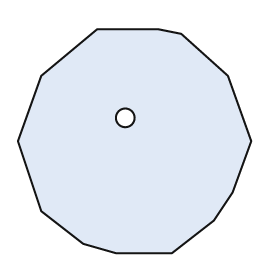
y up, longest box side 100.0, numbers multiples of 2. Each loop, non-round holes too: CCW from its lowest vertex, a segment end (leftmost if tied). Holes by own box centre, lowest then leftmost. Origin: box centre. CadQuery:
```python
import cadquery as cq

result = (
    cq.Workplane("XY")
    .moveTo(-8.0, -48.0)
    .lineTo(16.0, -48.0)
    .lineTo(34.0, -34.0)
    .lineTo(42.0, -22.0)
    .lineTo(50.0, 0.0)
    .lineTo(40.0, 28.0)
    .lineTo(20.0, 46.0)
    .lineTo(10.0, 48.0)
    .lineTo(-16.0, 48.0)
    .lineTo(-40.0, 28.0)
    .lineTo(-50.0, 0.0)
    .lineTo(-40.0, -30.0)
    .lineTo(-22.0, -44.0)
    .close()
    .moveTo(-4.0, 10.0)
    .circle(4.0)
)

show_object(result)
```